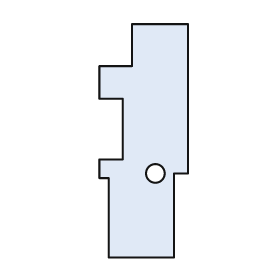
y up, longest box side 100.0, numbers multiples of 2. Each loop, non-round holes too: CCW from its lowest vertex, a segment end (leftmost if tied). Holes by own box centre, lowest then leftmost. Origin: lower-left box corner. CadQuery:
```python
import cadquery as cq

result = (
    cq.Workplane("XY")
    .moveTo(4.0, 0.0)
    .lineTo(32.0, 0.0)
    .lineTo(32.0, 36.0)
    .lineTo(38.0, 36.0)
    .lineTo(38.0, 100.0)
    .lineTo(14.0, 100.0)
    .lineTo(14.0, 82.0)
    .lineTo(0.0, 82.0)
    .lineTo(0.0, 68.0)
    .lineTo(10.0, 68.0)
    .lineTo(10.0, 42.0)
    .lineTo(0.0, 42.0)
    .lineTo(0.0, 34.0)
    .lineTo(4.0, 34.0)
    .close()
    .moveTo(24.0, 36.0)
    .circle(4.0)
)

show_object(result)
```